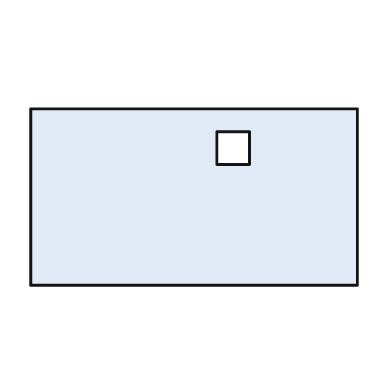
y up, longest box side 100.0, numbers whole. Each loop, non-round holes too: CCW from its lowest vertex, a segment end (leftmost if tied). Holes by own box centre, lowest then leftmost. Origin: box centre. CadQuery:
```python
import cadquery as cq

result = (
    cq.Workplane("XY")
    .moveTo(-50.0, -27.0)
    .lineTo(50.0, -27.0)
    .lineTo(50.0, 27.0)
    .lineTo(-50.0, 27.0)
    .close()
    .moveTo(7.0, 10.0)
    .lineTo(17.0, 10.0)
    .lineTo(17.0, 20.0)
    .lineTo(7.0, 20.0)
    .close()
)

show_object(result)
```